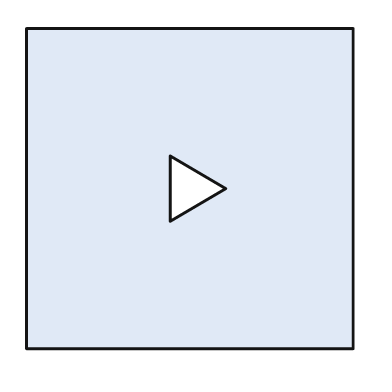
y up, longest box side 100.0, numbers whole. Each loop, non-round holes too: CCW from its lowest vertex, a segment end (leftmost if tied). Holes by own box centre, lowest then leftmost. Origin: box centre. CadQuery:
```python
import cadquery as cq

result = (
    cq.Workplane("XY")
    .moveTo(-50.0, -49.0)
    .lineTo(50.0, -49.0)
    .lineTo(50.0, 49.0)
    .lineTo(-50.0, 49.0)
    .close()
    .moveTo(-6.0, -10.0)
    .lineTo(11.0, 0.0)
    .lineTo(-6.0, 10.0)
    .close()
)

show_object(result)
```